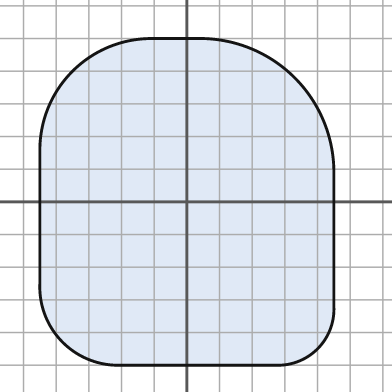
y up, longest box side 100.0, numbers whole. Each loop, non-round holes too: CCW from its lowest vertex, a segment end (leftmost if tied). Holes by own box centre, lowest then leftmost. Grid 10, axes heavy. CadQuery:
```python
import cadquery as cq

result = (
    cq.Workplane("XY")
    .moveTo(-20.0, -50.0)
    .lineTo(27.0, -50.0)
    .threePointArc((40.0, -45.0), (45.0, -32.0))
    .lineTo(45.0, 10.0)
    .threePointArc((33.0, 38.0), (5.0, 50.0))
    .lineTo(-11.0, 50.0)
    .threePointArc((-35.0, 40.0), (-45.0, 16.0))
    .lineTo(-45.0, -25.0)
    .threePointArc((-38.0, -43.0), (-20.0, -50.0))
    .close()
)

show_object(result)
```